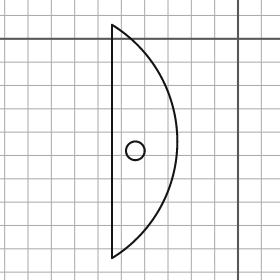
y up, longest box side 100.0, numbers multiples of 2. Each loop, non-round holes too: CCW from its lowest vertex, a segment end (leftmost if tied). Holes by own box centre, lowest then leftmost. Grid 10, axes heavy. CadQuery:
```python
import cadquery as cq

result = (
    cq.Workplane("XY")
    .moveTo(-54.0, -94.0)
    .threePointArc((-26.0, -44.0), (-54.0, 6.0))
    .close()
    .moveTo(-44.0, -48.0)
    .circle(4.0)
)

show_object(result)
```